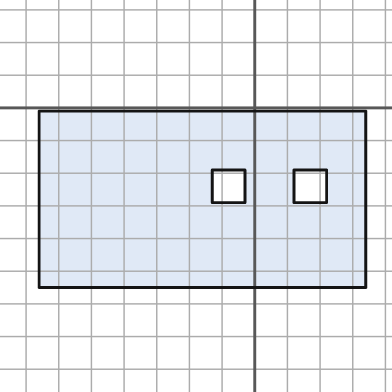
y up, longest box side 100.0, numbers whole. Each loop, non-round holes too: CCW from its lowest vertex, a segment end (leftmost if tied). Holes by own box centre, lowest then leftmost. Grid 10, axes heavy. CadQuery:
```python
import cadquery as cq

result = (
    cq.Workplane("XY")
    .moveTo(-66.0, -55.0)
    .lineTo(34.0, -55.0)
    .lineTo(34.0, -1.0)
    .lineTo(-66.0, -1.0)
    .close()
    .moveTo(-13.0, -29.0)
    .lineTo(-3.0, -29.0)
    .lineTo(-3.0, -19.0)
    .lineTo(-13.0, -19.0)
    .close()
    .moveTo(12.0, -29.0)
    .lineTo(22.0, -29.0)
    .lineTo(22.0, -19.0)
    .lineTo(12.0, -19.0)
    .close()
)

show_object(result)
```